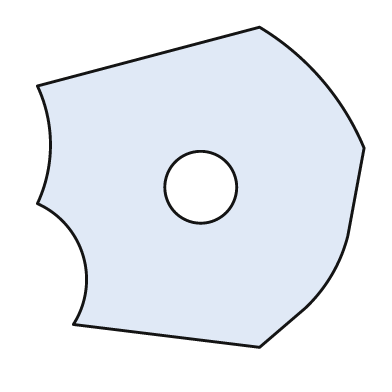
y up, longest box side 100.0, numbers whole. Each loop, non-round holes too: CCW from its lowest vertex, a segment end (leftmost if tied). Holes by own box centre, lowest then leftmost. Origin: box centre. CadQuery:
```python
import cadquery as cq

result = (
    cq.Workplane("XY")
    .moveTo(18.0, -49.0)
    .lineTo(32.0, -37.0)
    .threePointArc((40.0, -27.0), (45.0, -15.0))
    .lineTo(50.0, 12.0)
    .threePointArc((37.0, 33.0), (18.0, 49.0))
    .lineTo(-50.0, 31.0)
    .threePointArc((-46.0, 13.0), (-50.0, -5.0))
    .threePointArc((-36.0, -21.0), (-39.0, -42.0))
    .close()
    .moveTo(0.0, 0.0)
    .circle(11.0)
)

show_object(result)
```